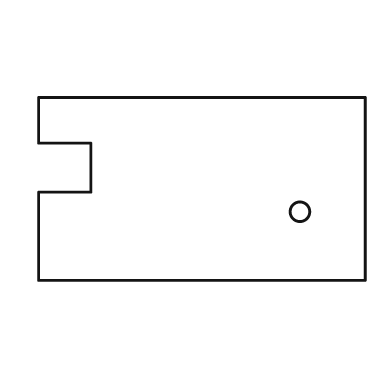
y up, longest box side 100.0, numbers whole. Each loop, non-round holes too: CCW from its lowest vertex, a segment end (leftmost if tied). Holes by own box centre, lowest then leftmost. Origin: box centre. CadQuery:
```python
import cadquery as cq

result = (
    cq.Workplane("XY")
    .moveTo(-50.0, -28.0)
    .lineTo(50.0, -28.0)
    .lineTo(50.0, 28.0)
    .lineTo(-50.0, 28.0)
    .lineTo(-50.0, 14.0)
    .lineTo(-34.0, 14.0)
    .lineTo(-34.0, -1.0)
    .lineTo(-50.0, -1.0)
    .close()
    .moveTo(30.0, -7.0)
    .circle(3.0)
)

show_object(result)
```